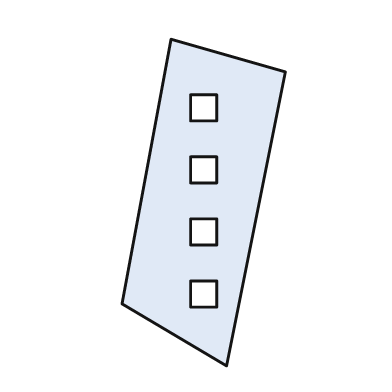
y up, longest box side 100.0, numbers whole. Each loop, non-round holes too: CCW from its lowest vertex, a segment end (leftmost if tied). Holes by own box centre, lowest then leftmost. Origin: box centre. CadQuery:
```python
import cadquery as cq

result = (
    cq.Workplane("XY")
    .moveTo(7.0, -50.0)
    .lineTo(25.0, 40.0)
    .lineTo(-10.0, 50.0)
    .lineTo(-25.0, -31.0)
    .close()
    .moveTo(-4.0, -32.0)
    .lineTo(4.0, -32.0)
    .lineTo(4.0, -24.0)
    .lineTo(-4.0, -24.0)
    .close()
    .moveTo(-4.0, -13.0)
    .lineTo(4.0, -13.0)
    .lineTo(4.0, -5.0)
    .lineTo(-4.0, -5.0)
    .close()
    .moveTo(-4.0, 6.0)
    .lineTo(4.0, 6.0)
    .lineTo(4.0, 14.0)
    .lineTo(-4.0, 14.0)
    .close()
    .moveTo(-4.0, 25.0)
    .lineTo(4.0, 25.0)
    .lineTo(4.0, 33.0)
    .lineTo(-4.0, 33.0)
    .close()
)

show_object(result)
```